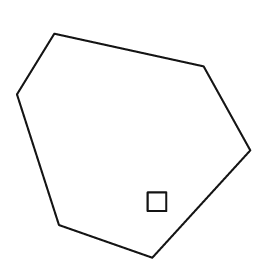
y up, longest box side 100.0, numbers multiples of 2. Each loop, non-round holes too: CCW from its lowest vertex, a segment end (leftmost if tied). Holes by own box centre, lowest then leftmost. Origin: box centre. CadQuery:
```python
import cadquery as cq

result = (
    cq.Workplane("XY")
    .moveTo(8.0, -48.0)
    .lineTo(50.0, -2.0)
    .lineTo(30.0, 34.0)
    .lineTo(-34.0, 48.0)
    .lineTo(-50.0, 22.0)
    .lineTo(-32.0, -34.0)
    .close()
    .moveTo(6.0, -28.0)
    .lineTo(14.0, -28.0)
    .lineTo(14.0, -20.0)
    .lineTo(6.0, -20.0)
    .close()
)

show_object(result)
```